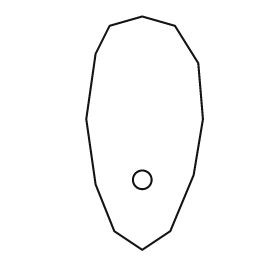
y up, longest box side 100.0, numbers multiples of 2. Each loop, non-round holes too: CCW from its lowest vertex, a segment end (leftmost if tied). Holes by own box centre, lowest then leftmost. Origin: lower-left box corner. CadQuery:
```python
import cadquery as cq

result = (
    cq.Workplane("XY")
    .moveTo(24.0, 0.0)
    .lineTo(36.0, 8.0)
    .lineTo(46.0, 32.0)
    .lineTo(50.0, 56.0)
    .lineTo(48.0, 80.0)
    .lineTo(38.0, 96.0)
    .lineTo(24.0, 100.0)
    .lineTo(10.0, 96.0)
    .lineTo(4.0, 84.0)
    .lineTo(0.0, 56.0)
    .lineTo(4.0, 28.0)
    .lineTo(12.0, 8.0)
    .close()
    .moveTo(24.0, 30.0)
    .circle(4.0)
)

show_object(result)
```